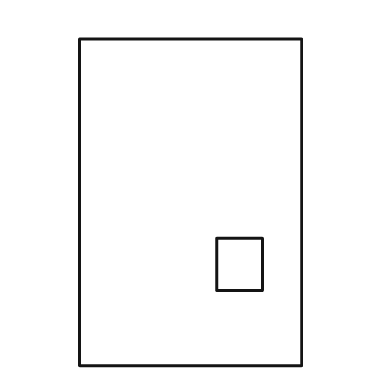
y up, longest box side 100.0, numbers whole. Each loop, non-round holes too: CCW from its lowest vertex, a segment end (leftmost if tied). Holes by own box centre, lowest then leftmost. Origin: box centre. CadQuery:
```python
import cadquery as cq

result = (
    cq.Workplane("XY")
    .moveTo(-34.0, -50.0)
    .lineTo(34.0, -50.0)
    .lineTo(34.0, 50.0)
    .lineTo(-34.0, 50.0)
    .close()
    .moveTo(8.0, -27.0)
    .lineTo(22.0, -27.0)
    .lineTo(22.0, -11.0)
    .lineTo(8.0, -11.0)
    .close()
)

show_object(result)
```